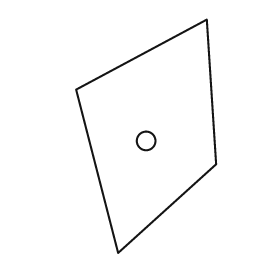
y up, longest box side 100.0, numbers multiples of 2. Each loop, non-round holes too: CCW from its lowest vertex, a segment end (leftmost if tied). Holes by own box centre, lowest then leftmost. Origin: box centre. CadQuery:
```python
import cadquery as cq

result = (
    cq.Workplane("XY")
    .moveTo(-12.0, -50.0)
    .lineTo(30.0, -12.0)
    .lineTo(26.0, 50.0)
    .lineTo(-30.0, 20.0)
    .close()
    .moveTo(0.0, -2.0)
    .circle(4.0)
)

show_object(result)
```